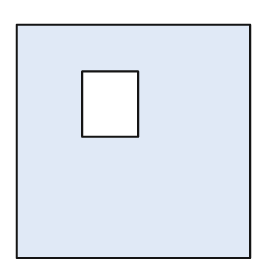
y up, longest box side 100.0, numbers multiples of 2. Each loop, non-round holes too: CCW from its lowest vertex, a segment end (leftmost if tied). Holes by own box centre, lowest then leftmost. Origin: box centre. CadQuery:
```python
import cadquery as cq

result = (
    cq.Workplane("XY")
    .moveTo(-50.0, -50.0)
    .lineTo(50.0, -50.0)
    .lineTo(50.0, 50.0)
    .lineTo(-50.0, 50.0)
    .close()
    .moveTo(-22.0, 2.0)
    .lineTo(2.0, 2.0)
    .lineTo(2.0, 30.0)
    .lineTo(-22.0, 30.0)
    .close()
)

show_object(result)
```